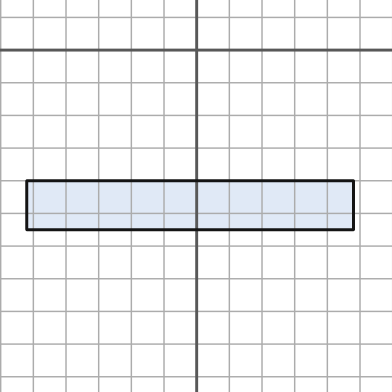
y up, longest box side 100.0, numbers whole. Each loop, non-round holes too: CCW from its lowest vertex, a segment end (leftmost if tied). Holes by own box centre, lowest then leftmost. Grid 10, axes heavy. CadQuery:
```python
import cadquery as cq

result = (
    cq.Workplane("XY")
    .moveTo(-52.0, -55.0)
    .lineTo(48.0, -55.0)
    .lineTo(48.0, -40.0)
    .lineTo(-52.0, -40.0)
    .close()
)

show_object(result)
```